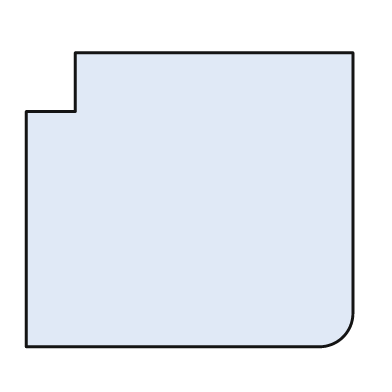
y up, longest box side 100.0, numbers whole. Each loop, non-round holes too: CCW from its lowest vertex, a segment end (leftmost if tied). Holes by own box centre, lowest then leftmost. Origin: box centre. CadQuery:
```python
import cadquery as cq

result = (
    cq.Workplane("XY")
    .moveTo(-50.0, -45.0)
    .lineTo(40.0, -45.0)
    .threePointArc((47.0, -42.0), (50.0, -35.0))
    .lineTo(50.0, 45.0)
    .lineTo(-35.0, 45.0)
    .lineTo(-35.0, 27.0)
    .lineTo(-50.0, 27.0)
    .close()
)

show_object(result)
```